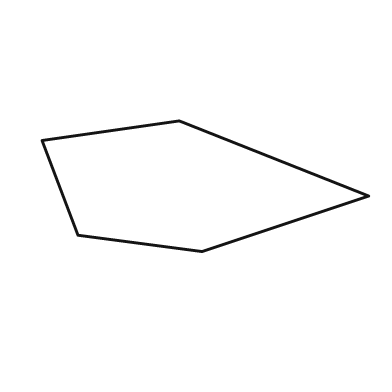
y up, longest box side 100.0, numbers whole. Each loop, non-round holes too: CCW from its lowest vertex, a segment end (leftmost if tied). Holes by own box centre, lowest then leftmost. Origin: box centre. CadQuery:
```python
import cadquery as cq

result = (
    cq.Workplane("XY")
    .moveTo(-1.0, -20.0)
    .lineTo(50.0, -3.0)
    .lineTo(-8.0, 20.0)
    .lineTo(-50.0, 14.0)
    .lineTo(-39.0, -15.0)
    .close()
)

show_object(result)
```